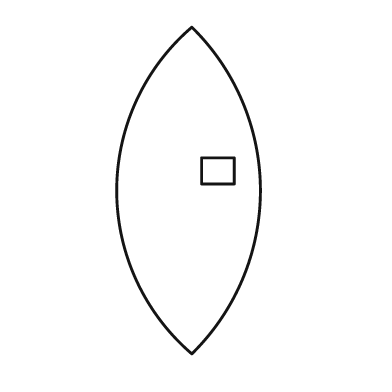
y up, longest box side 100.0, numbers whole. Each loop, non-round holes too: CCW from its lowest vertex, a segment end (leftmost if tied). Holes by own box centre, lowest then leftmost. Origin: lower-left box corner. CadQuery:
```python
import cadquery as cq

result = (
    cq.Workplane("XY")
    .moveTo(23.0, 0.0)
    .threePointArc((44.0, 50.0), (23.0, 100.0))
    .threePointArc((0.0, 50.0), (23.0, 0.0))
    .close()
    .moveTo(26.0, 52.0)
    .lineTo(36.0, 52.0)
    .lineTo(36.0, 60.0)
    .lineTo(26.0, 60.0)
    .close()
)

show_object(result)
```